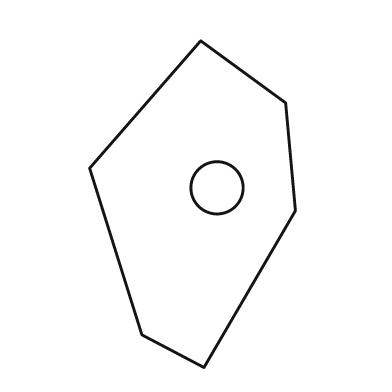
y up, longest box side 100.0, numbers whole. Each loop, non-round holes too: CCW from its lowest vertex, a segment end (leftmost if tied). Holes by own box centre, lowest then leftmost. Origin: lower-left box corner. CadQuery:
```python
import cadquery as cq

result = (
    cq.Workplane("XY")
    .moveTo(35.0, 0.0)
    .lineTo(63.0, 48.0)
    .lineTo(60.0, 81.0)
    .lineTo(34.0, 100.0)
    .lineTo(0.0, 61.0)
    .lineTo(16.0, 10.0)
    .close()
    .moveTo(39.0, 55.0)
    .circle(8.0)
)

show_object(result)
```